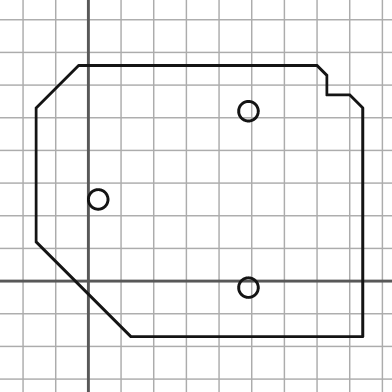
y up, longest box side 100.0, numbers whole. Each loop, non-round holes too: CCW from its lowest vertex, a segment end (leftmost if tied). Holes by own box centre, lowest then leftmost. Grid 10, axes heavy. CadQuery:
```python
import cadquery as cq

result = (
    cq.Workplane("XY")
    .moveTo(13.0, -17.0)
    .lineTo(84.0, -17.0)
    .lineTo(84.0, 53.0)
    .lineTo(80.0, 57.0)
    .lineTo(73.0, 57.0)
    .lineTo(73.0, 63.0)
    .lineTo(70.0, 66.0)
    .lineTo(-3.0, 66.0)
    .lineTo(-16.0, 53.0)
    .lineTo(-16.0, 12.0)
    .close()
    .moveTo(49.0, -2.0)
    .circle(3.0)
    .moveTo(3.0, 25.0)
    .circle(3.0)
    .moveTo(49.0, 52.0)
    .circle(3.0)
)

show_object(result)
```